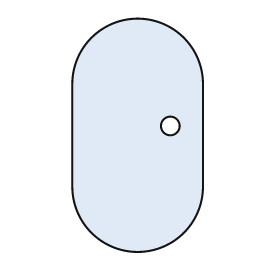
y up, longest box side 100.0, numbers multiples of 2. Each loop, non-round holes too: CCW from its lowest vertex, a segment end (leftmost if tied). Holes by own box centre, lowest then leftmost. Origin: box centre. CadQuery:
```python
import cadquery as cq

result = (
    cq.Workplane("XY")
    .moveTo(-28.0, -22.0)
    .threePointArc((0.0, -50.0), (28.0, -22.0))
    .lineTo(28.0, 22.0)
    .threePointArc((0.0, 50.0), (-28.0, 22.0))
    .close()
    .moveTo(14.0, 4.0)
    .circle(4.0)
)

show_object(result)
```